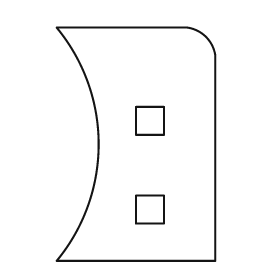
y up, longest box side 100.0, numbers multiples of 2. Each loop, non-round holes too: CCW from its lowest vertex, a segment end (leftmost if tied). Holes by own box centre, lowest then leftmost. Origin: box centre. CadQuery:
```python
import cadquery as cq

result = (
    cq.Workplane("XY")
    .moveTo(-34.0, -50.0)
    .lineTo(34.0, -50.0)
    .lineTo(34.0, 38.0)
    .threePointArc((30.0, 46.0), (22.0, 50.0))
    .lineTo(-34.0, 50.0)
    .threePointArc((-16.0, 0.0), (-34.0, -50.0))
    .close()
    .moveTo(0.0, -34.0)
    .lineTo(12.0, -34.0)
    .lineTo(12.0, -22.0)
    .lineTo(0.0, -22.0)
    .close()
    .moveTo(0.0, 4.0)
    .lineTo(12.0, 4.0)
    .lineTo(12.0, 16.0)
    .lineTo(0.0, 16.0)
    .close()
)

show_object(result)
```